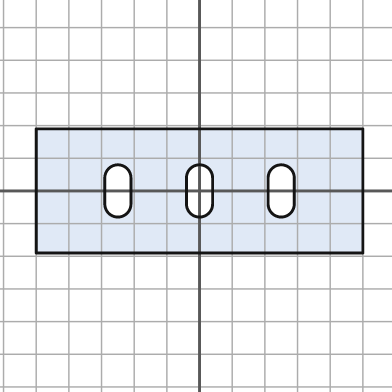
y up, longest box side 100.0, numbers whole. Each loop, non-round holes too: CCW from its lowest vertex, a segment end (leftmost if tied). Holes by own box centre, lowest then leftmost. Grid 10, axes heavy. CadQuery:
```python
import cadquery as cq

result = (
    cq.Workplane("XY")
    .moveTo(-50.0, -19.0)
    .lineTo(50.0, -19.0)
    .lineTo(50.0, 19.0)
    .lineTo(-50.0, 19.0)
    .close()
    .moveTo(-29.0, -4.0)
    .threePointArc((-25.0, -8.0), (-21.0, -4.0))
    .lineTo(-21.0, 4.0)
    .threePointArc((-25.0, 8.0), (-29.0, 4.0))
    .close()
    .moveTo(-4.0, -4.0)
    .threePointArc((0.0, -8.0), (4.0, -4.0))
    .lineTo(4.0, 4.0)
    .threePointArc((0.0, 8.0), (-4.0, 4.0))
    .close()
    .moveTo(21.0, -4.0)
    .threePointArc((25.0, -8.0), (29.0, -4.0))
    .lineTo(29.0, 4.0)
    .threePointArc((25.0, 8.0), (21.0, 4.0))
    .close()
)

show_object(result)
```